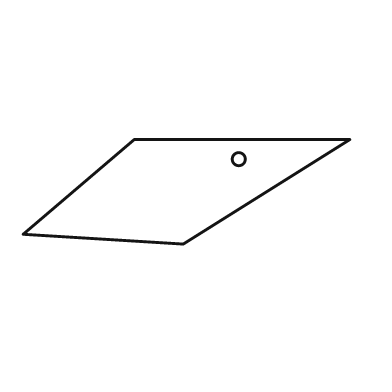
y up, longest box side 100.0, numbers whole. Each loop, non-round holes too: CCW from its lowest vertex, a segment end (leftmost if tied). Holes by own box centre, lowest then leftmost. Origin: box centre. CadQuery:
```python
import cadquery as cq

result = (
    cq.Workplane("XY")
    .moveTo(-1.0, -16.0)
    .lineTo(50.0, 16.0)
    .lineTo(-16.0, 16.0)
    .lineTo(-50.0, -13.0)
    .close()
    .moveTo(16.0, 10.0)
    .circle(2.0)
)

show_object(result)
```